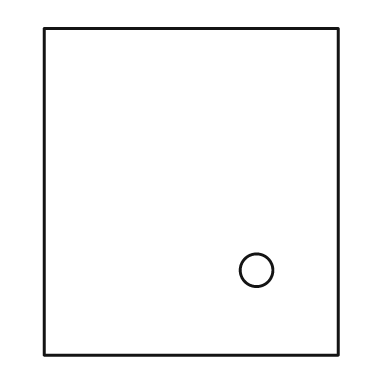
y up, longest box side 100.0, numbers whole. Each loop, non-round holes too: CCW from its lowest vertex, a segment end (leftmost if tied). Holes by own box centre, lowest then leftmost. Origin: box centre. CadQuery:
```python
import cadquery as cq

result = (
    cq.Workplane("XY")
    .moveTo(-45.0, -50.0)
    .lineTo(45.0, -50.0)
    .lineTo(45.0, 50.0)
    .lineTo(-45.0, 50.0)
    .close()
    .moveTo(20.0, -24.0)
    .circle(5.0)
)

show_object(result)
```